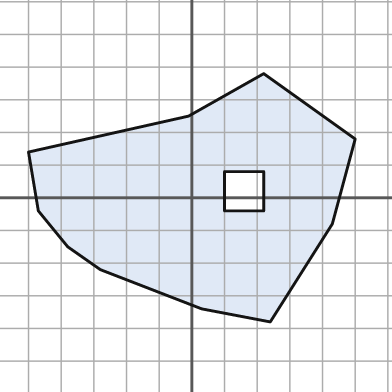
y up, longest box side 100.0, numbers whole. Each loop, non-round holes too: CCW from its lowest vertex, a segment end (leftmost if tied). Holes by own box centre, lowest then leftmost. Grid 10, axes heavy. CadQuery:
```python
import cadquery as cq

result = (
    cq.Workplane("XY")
    .moveTo(24.0, -38.0)
    .lineTo(43.0, -8.0)
    .lineTo(50.0, 18.0)
    .lineTo(22.0, 38.0)
    .lineTo(-1.0, 25.0)
    .lineTo(-50.0, 14.0)
    .lineTo(-47.0, -4.0)
    .lineTo(-38.0, -15.0)
    .lineTo(-28.0, -22.0)
    .lineTo(3.0, -34.0)
    .close()
    .moveTo(10.0, -4.0)
    .lineTo(22.0, -4.0)
    .lineTo(22.0, 8.0)
    .lineTo(10.0, 8.0)
    .close()
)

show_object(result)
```